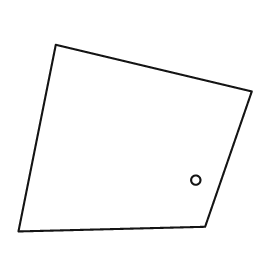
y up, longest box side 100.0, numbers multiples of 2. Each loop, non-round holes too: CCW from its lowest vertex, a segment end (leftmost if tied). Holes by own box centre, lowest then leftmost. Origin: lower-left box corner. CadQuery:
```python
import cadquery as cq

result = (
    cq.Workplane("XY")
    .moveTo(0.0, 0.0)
    .lineTo(80.0, 2.0)
    .lineTo(100.0, 60.0)
    .lineTo(16.0, 80.0)
    .close()
    .moveTo(76.0, 22.0)
    .circle(2.0)
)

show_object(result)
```